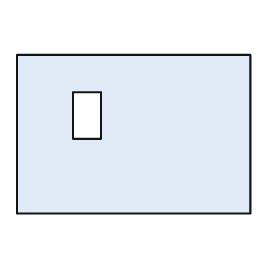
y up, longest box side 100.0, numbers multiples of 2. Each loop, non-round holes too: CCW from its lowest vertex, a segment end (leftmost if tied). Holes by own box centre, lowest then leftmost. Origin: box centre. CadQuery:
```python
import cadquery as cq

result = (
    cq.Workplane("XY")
    .moveTo(-50.0, -34.0)
    .lineTo(50.0, -34.0)
    .lineTo(50.0, 34.0)
    .lineTo(-50.0, 34.0)
    .close()
    .moveTo(-26.0, -2.0)
    .lineTo(-14.0, -2.0)
    .lineTo(-14.0, 18.0)
    .lineTo(-26.0, 18.0)
    .close()
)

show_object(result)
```